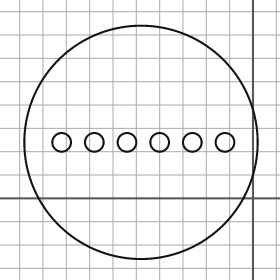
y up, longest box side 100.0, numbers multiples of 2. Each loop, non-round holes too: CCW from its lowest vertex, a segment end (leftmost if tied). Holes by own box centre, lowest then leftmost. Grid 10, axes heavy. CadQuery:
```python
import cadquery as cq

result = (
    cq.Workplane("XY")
    .moveTo(-48.0, 24.0)
    .circle(50.0)
    .moveTo(-82.0, 24.0)
    .circle(4.0)
    .moveTo(-68.0, 24.0)
    .circle(4.0)
    .moveTo(-54.0, 24.0)
    .circle(4.0)
    .moveTo(-40.0, 24.0)
    .circle(4.0)
    .moveTo(-26.0, 24.0)
    .circle(4.0)
    .moveTo(-12.0, 24.0)
    .circle(4.0)
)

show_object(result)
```